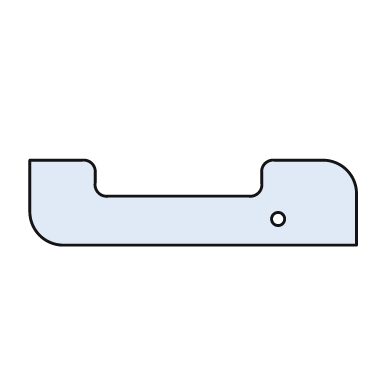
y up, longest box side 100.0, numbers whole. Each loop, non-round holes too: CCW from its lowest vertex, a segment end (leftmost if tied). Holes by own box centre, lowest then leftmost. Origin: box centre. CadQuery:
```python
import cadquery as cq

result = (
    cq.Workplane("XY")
    .moveTo(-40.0, -13.0)
    .lineTo(50.0, -13.0)
    .lineTo(50.0, 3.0)
    .threePointArc((47.0, 10.0), (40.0, 13.0))
    .lineTo(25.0, 13.0)
    .threePointArc((22.0, 12.0), (21.0, 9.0))
    .lineTo(21.0, 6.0)
    .threePointArc((20.0, 3.0), (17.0, 2.0))
    .lineTo(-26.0, 2.0)
    .threePointArc((-29.0, 3.0), (-30.0, 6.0))
    .lineTo(-30.0, 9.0)
    .threePointArc((-31.0, 12.0), (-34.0, 13.0))
    .lineTo(-50.0, 13.0)
    .lineTo(-50.0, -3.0)
    .threePointArc((-47.0, -10.0), (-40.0, -13.0))
    .close()
    .moveTo(26.0, -5.0)
    .circle(2.0)
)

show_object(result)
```